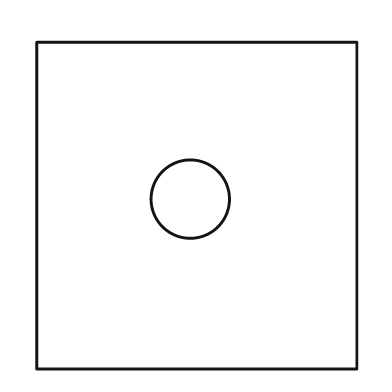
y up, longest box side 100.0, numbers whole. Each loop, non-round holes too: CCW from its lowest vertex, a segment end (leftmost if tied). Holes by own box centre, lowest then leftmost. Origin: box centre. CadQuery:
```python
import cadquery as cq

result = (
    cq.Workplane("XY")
    .moveTo(-49.0, -50.0)
    .lineTo(49.0, -50.0)
    .lineTo(49.0, 50.0)
    .lineTo(-49.0, 50.0)
    .close()
    .moveTo(-2.0, 2.0)
    .circle(12.0)
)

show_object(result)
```